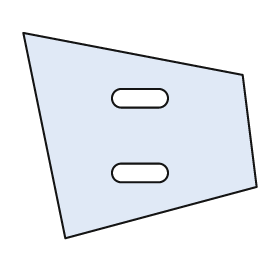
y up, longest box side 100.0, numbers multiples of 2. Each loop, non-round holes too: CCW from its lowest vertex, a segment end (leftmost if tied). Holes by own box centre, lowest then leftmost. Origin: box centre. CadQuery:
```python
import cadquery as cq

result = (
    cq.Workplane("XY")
    .moveTo(-32.0, -44.0)
    .lineTo(50.0, -22.0)
    .lineTo(44.0, 26.0)
    .lineTo(-50.0, 44.0)
    .close()
    .moveTo(-8.0, -20.0)
    .lineTo(8.0, -20.0)
    .threePointArc((12.0, -16.0), (8.0, -12.0))
    .lineTo(-8.0, -12.0)
    .threePointArc((-12.0, -16.0), (-8.0, -20.0))
    .close()
    .moveTo(-8.0, 12.0)
    .lineTo(8.0, 12.0)
    .threePointArc((12.0, 16.0), (8.0, 20.0))
    .lineTo(-8.0, 20.0)
    .threePointArc((-12.0, 16.0), (-8.0, 12.0))
    .close()
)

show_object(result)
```